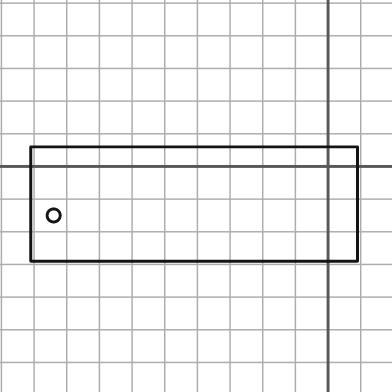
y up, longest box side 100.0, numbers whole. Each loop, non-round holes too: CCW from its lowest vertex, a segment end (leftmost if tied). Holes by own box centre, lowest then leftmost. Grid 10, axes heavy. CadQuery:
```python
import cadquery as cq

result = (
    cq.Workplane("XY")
    .moveTo(-91.0, -29.0)
    .lineTo(9.0, -29.0)
    .lineTo(9.0, 6.0)
    .lineTo(-91.0, 6.0)
    .close()
    .moveTo(-84.0, -15.0)
    .circle(2.0)
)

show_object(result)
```